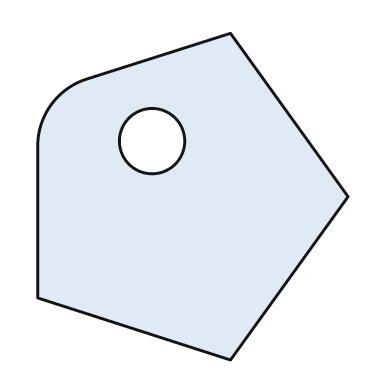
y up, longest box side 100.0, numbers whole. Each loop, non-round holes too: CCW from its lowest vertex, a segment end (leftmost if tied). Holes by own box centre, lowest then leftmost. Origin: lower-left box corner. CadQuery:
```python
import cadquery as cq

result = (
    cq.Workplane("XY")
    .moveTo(59.0, 0.0)
    .lineTo(95.0, 50.0)
    .lineTo(59.0, 100.0)
    .lineTo(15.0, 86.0)
    .threePointArc((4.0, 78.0), (0.0, 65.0))
    .lineTo(0.0, 19.0)
    .close()
    .moveTo(35.0, 67.0)
    .circle(10.0)
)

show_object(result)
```